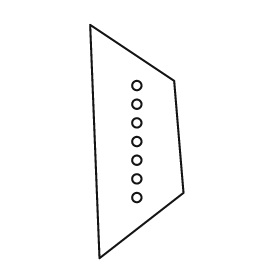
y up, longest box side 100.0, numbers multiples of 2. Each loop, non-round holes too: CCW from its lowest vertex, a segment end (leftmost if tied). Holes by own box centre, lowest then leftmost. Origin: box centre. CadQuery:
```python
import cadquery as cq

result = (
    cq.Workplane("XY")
    .moveTo(-16.0, -50.0)
    .lineTo(20.0, -22.0)
    .lineTo(16.0, 26.0)
    .lineTo(-20.0, 50.0)
    .close()
    .moveTo(0.0, -24.0)
    .circle(2.0)
    .moveTo(0.0, -16.0)
    .circle(2.0)
    .moveTo(0.0, -8.0)
    .circle(2.0)
    .moveTo(0.0, 0.0)
    .circle(2.0)
    .moveTo(0.0, 8.0)
    .circle(2.0)
    .moveTo(0.0, 16.0)
    .circle(2.0)
    .moveTo(0.0, 24.0)
    .circle(2.0)
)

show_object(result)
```